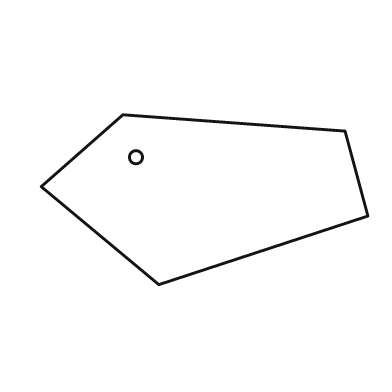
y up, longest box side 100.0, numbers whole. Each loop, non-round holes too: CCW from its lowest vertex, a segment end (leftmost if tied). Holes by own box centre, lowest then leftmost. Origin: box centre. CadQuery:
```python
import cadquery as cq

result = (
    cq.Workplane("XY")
    .moveTo(-14.0, -26.0)
    .lineTo(50.0, -5.0)
    .lineTo(43.0, 21.0)
    .lineTo(-25.0, 26.0)
    .lineTo(-50.0, 4.0)
    .close()
    .moveTo(-21.0, 13.0)
    .circle(2.0)
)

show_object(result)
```